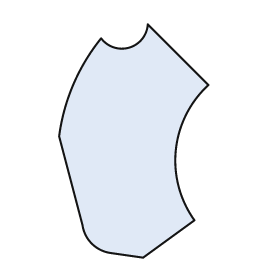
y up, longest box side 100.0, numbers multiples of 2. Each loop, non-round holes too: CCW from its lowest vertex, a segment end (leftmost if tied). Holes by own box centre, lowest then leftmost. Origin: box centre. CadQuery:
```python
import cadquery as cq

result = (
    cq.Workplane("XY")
    .moveTo(4.0, -50.0)
    .lineTo(26.0, -34.0)
    .threePointArc((18.0, -4.0), (32.0, 24.0))
    .lineTo(6.0, 50.0)
    .threePointArc((-2.0, 40.0), (-14.0, 44.0))
    .threePointArc((-26.0, 24.0), (-32.0, 2.0))
    .lineTo(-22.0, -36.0)
    .threePointArc((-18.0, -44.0), (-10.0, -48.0))
    .close()
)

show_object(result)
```